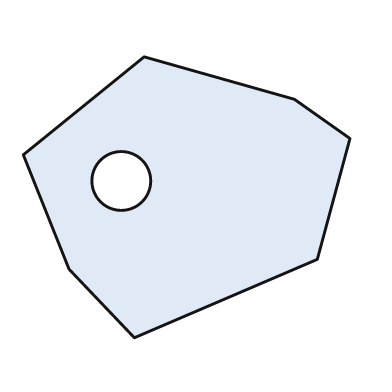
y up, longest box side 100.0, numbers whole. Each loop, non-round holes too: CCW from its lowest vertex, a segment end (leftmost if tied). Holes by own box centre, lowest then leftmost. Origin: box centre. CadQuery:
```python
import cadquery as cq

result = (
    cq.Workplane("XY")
    .moveTo(-16.0, -43.0)
    .lineTo(40.0, -19.0)
    .lineTo(50.0, 18.0)
    .lineTo(33.0, 30.0)
    .lineTo(-13.0, 43.0)
    .lineTo(-50.0, 13.0)
    .lineTo(-36.0, -22.0)
    .close()
    .moveTo(-20.0, 5.0)
    .circle(9.0)
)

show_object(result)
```